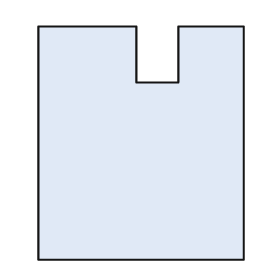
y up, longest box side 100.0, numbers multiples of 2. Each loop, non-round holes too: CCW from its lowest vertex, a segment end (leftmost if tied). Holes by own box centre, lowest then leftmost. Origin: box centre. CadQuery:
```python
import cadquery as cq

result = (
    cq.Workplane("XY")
    .moveTo(-44.0, -50.0)
    .lineTo(44.0, -50.0)
    .lineTo(44.0, 50.0)
    .lineTo(16.0, 50.0)
    .lineTo(16.0, 26.0)
    .lineTo(-2.0, 26.0)
    .lineTo(-2.0, 50.0)
    .lineTo(-44.0, 50.0)
    .close()
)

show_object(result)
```